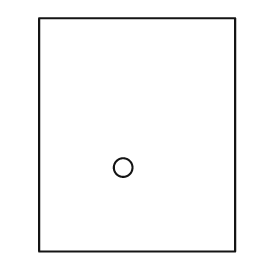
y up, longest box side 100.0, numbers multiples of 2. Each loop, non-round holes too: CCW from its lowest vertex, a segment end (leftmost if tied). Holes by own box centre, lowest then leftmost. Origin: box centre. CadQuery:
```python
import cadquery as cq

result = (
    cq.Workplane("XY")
    .moveTo(-42.0, -50.0)
    .lineTo(42.0, -50.0)
    .lineTo(42.0, 50.0)
    .lineTo(-42.0, 50.0)
    .close()
    .moveTo(-6.0, -14.0)
    .circle(4.0)
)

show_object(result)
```